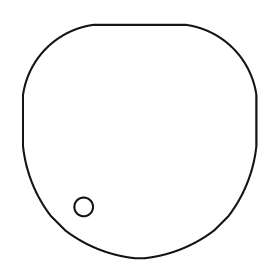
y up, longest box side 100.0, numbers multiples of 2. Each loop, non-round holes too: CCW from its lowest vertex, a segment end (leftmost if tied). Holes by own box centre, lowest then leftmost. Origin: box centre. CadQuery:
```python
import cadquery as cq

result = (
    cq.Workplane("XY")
    .moveTo(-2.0, -50.0)
    .lineTo(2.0, -50.0)
    .threePointArc((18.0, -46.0), (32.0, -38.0))
    .lineTo(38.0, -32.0)
    .threePointArc((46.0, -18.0), (50.0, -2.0))
    .lineTo(50.0, 20.0)
    .threePointArc((40.0, 40.0), (20.0, 50.0))
    .lineTo(-20.0, 50.0)
    .threePointArc((-40.0, 40.0), (-50.0, 20.0))
    .lineTo(-50.0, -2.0)
    .threePointArc((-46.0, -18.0), (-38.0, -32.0))
    .lineTo(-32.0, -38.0)
    .threePointArc((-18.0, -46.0), (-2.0, -50.0))
    .close()
    .moveTo(-24.0, -28.0)
    .circle(4.0)
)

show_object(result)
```